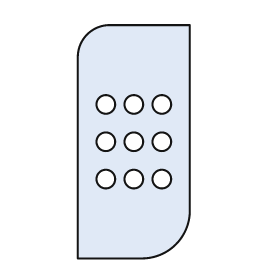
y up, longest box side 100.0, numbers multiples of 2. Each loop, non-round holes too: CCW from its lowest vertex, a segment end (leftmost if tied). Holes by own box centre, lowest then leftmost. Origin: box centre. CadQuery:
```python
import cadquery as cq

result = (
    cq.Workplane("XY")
    .moveTo(-24.0, -50.0)
    .lineTo(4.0, -50.0)
    .threePointArc((18.0, -44.0), (24.0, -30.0))
    .lineTo(24.0, 50.0)
    .lineTo(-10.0, 50.0)
    .threePointArc((-20.0, 46.0), (-24.0, 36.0))
    .close()
    .moveTo(-12.0, -16.0)
    .circle(4.0)
    .moveTo(0.0, -16.0)
    .circle(4.0)
    .moveTo(12.0, -16.0)
    .circle(4.0)
    .moveTo(-12.0, 0.0)
    .circle(4.0)
    .moveTo(0.0, 0.0)
    .circle(4.0)
    .moveTo(12.0, 0.0)
    .circle(4.0)
    .moveTo(-12.0, 16.0)
    .circle(4.0)
    .moveTo(0.0, 16.0)
    .circle(4.0)
    .moveTo(12.0, 16.0)
    .circle(4.0)
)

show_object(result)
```